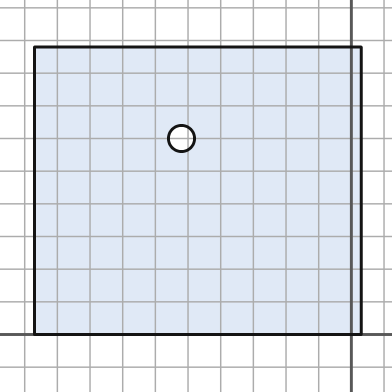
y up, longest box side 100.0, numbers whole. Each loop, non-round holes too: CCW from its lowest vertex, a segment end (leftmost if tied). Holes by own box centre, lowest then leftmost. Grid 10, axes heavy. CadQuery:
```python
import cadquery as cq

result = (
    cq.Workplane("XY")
    .moveTo(-97.0, 0.0)
    .lineTo(3.0, 0.0)
    .lineTo(3.0, 88.0)
    .lineTo(-97.0, 88.0)
    .close()
    .moveTo(-52.0, 60.0)
    .circle(4.0)
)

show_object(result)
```